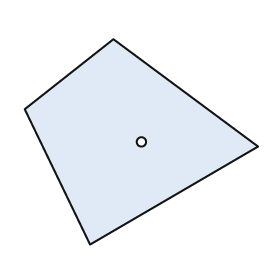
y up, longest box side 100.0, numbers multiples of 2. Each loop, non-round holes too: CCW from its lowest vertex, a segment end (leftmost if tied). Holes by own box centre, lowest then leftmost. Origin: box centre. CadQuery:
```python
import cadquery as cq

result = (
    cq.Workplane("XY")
    .moveTo(-22.0, -44.0)
    .lineTo(50.0, -2.0)
    .lineTo(-12.0, 44.0)
    .lineTo(-50.0, 14.0)
    .close()
    .moveTo(0.0, 0.0)
    .circle(2.0)
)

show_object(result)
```